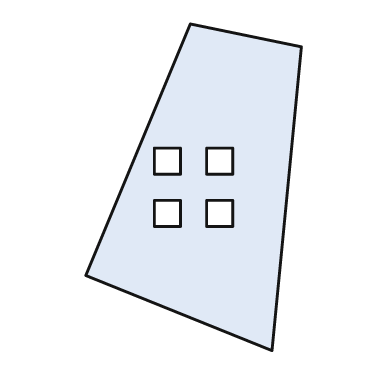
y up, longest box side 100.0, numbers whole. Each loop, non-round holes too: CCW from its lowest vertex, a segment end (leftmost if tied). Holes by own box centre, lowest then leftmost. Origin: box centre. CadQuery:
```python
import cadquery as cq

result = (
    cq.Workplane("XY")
    .moveTo(24.0, -50.0)
    .lineTo(33.0, 43.0)
    .lineTo(-1.0, 50.0)
    .lineTo(-33.0, -27.0)
    .close()
    .moveTo(-12.0, -12.0)
    .lineTo(-4.0, -12.0)
    .lineTo(-4.0, -4.0)
    .lineTo(-12.0, -4.0)
    .close()
    .moveTo(4.0, -12.0)
    .lineTo(12.0, -12.0)
    .lineTo(12.0, -4.0)
    .lineTo(4.0, -4.0)
    .close()
    .moveTo(-12.0, 4.0)
    .lineTo(-4.0, 4.0)
    .lineTo(-4.0, 12.0)
    .lineTo(-12.0, 12.0)
    .close()
    .moveTo(4.0, 4.0)
    .lineTo(12.0, 4.0)
    .lineTo(12.0, 12.0)
    .lineTo(4.0, 12.0)
    .close()
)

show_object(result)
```